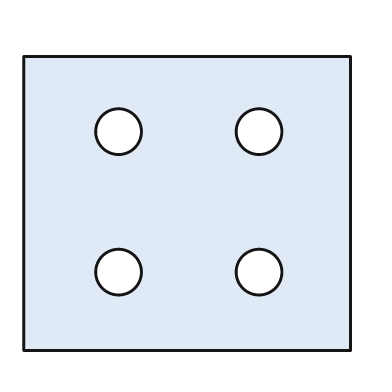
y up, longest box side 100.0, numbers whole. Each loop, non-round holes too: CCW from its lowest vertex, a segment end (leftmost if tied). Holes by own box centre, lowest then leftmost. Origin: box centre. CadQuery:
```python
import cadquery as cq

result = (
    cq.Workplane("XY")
    .moveTo(-50.0, -45.0)
    .lineTo(50.0, -45.0)
    .lineTo(50.0, 45.0)
    .lineTo(-50.0, 45.0)
    .close()
    .moveTo(-21.0, -21.0)
    .circle(7.0)
    .moveTo(22.0, -21.0)
    .circle(7.0)
    .moveTo(-21.0, 22.0)
    .circle(7.0)
    .moveTo(22.0, 22.0)
    .circle(7.0)
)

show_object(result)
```